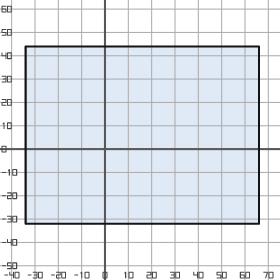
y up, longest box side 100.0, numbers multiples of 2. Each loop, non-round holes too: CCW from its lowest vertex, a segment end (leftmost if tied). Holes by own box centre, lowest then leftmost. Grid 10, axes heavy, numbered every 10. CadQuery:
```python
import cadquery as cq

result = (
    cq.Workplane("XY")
    .moveTo(-34.0, -32.0)
    .lineTo(66.0, -32.0)
    .lineTo(66.0, 44.0)
    .lineTo(-34.0, 44.0)
    .close()
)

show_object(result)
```